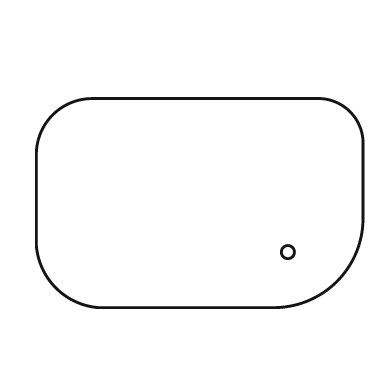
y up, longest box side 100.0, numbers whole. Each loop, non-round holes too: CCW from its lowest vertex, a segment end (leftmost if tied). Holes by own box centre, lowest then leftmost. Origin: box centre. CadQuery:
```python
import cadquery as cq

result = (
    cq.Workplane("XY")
    .moveTo(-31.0, -32.0)
    .lineTo(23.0, -32.0)
    .threePointArc((42.0, -24.0), (50.0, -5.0))
    .lineTo(50.0, 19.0)
    .threePointArc((46.0, 28.0), (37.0, 32.0))
    .lineTo(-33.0, 32.0)
    .threePointArc((-45.0, 27.0), (-50.0, 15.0))
    .lineTo(-50.0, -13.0)
    .threePointArc((-44.0, -26.0), (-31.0, -32.0))
    .close()
    .moveTo(27.0, -15.0)
    .circle(2.0)
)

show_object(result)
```